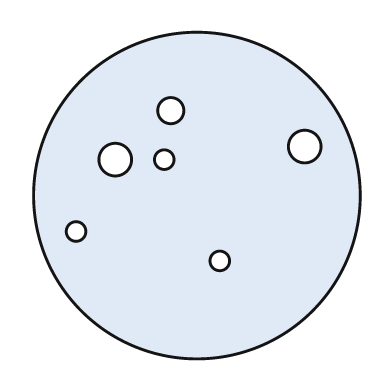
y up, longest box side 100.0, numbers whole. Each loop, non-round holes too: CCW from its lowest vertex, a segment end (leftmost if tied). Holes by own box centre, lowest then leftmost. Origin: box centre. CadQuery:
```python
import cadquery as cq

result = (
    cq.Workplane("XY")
    .moveTo(0.0, 0.0)
    .circle(50.0)
    .moveTo(7.0, -20.0)
    .circle(3.0)
    .moveTo(-37.0, -11.0)
    .circle(3.0)
    .moveTo(-25.0, 11.0)
    .circle(5.0)
    .moveTo(-10.0, 11.0)
    .circle(3.0)
    .moveTo(33.0, 15.0)
    .circle(5.0)
    .moveTo(-8.0, 26.0)
    .circle(4.0)
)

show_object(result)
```